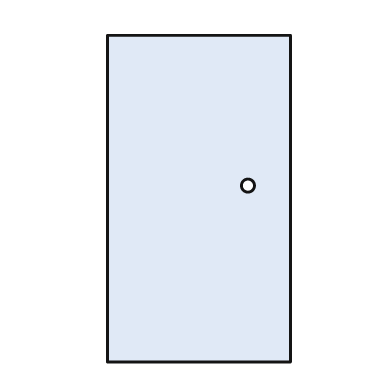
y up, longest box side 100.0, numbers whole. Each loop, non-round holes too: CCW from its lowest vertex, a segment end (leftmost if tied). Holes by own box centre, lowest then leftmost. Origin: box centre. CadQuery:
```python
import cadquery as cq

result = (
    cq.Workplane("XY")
    .moveTo(-28.0, -50.0)
    .lineTo(28.0, -50.0)
    .lineTo(28.0, 50.0)
    .lineTo(-28.0, 50.0)
    .close()
    .moveTo(15.0, 4.0)
    .circle(2.0)
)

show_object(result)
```